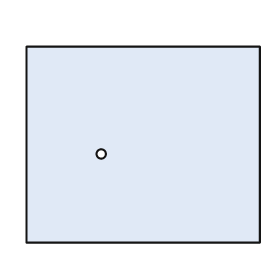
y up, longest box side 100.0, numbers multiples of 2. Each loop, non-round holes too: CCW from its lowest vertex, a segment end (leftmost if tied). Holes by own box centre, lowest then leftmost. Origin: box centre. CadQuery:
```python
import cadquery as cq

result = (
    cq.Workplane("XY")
    .moveTo(-50.0, -42.0)
    .lineTo(50.0, -42.0)
    .lineTo(50.0, 42.0)
    .lineTo(-50.0, 42.0)
    .close()
    .moveTo(-18.0, -4.0)
    .circle(2.0)
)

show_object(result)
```